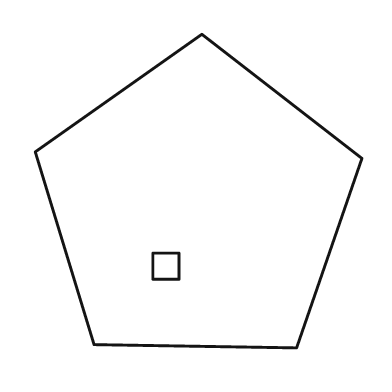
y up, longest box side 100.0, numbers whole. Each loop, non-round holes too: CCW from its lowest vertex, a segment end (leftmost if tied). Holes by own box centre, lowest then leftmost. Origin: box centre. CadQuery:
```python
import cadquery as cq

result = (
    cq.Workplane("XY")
    .moveTo(30.0, -48.0)
    .lineTo(50.0, 10.0)
    .lineTo(1.0, 48.0)
    .lineTo(-50.0, 12.0)
    .lineTo(-32.0, -47.0)
    .close()
    .moveTo(-14.0, -27.0)
    .lineTo(-6.0, -27.0)
    .lineTo(-6.0, -19.0)
    .lineTo(-14.0, -19.0)
    .close()
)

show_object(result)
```